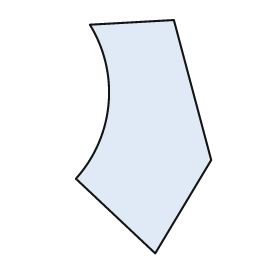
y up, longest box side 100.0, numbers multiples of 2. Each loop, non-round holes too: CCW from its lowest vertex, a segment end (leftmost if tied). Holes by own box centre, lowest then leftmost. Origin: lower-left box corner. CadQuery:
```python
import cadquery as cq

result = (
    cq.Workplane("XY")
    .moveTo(34.0, 0.0)
    .lineTo(58.0, 40.0)
    .lineTo(42.0, 100.0)
    .lineTo(6.0, 98.0)
    .threePointArc((14.0, 64.0), (0.0, 32.0))
    .close()
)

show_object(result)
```